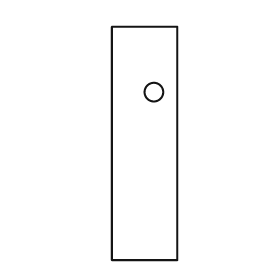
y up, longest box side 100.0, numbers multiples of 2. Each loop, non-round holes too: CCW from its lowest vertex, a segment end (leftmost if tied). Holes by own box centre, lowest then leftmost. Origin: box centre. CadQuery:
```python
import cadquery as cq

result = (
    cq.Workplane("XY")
    .moveTo(-14.0, -50.0)
    .lineTo(14.0, -50.0)
    .lineTo(14.0, 50.0)
    .lineTo(-14.0, 50.0)
    .close()
    .moveTo(4.0, 22.0)
    .circle(4.0)
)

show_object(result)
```